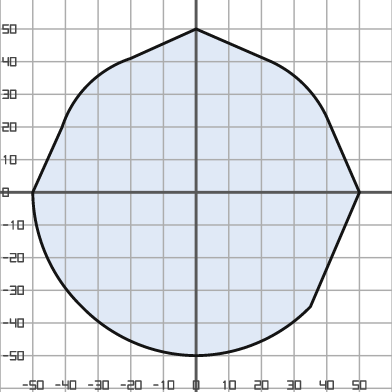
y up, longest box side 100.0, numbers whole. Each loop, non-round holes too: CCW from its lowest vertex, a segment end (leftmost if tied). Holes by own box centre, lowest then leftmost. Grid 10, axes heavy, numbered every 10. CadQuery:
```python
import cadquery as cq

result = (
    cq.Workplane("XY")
    .moveTo(0.0, -50.0)
    .threePointArc((19.0, -46.0), (35.0, -35.0))
    .lineTo(50.0, 0.0)
    .lineTo(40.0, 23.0)
    .threePointArc((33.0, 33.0), (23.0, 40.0))
    .lineTo(0.0, 50.0)
    .lineTo(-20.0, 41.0)
    .threePointArc((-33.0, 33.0), (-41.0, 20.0))
    .lineTo(-50.0, 0.0)
    .threePointArc((-46.0, -19.0), (-35.0, -35.0))
    .threePointArc((-19.0, -46.0), (0.0, -50.0))
    .close()
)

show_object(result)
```